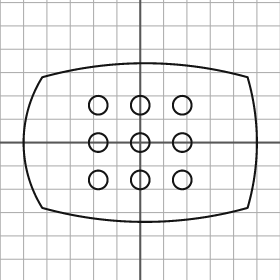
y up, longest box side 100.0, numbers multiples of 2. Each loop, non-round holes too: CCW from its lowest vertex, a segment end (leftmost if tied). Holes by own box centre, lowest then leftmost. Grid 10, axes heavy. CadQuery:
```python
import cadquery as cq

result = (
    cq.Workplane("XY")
    .moveTo(-42.0, -28.0)
    .threePointArc((2.0, -34.0), (46.0, -28.0))
    .threePointArc((50.0, 0.0), (46.0, 28.0))
    .threePointArc((2.0, 34.0), (-42.0, 28.0))
    .threePointArc((-50.0, 0.0), (-42.0, -28.0))
    .close()
    .moveTo(-18.0, -16.0)
    .circle(4.0)
    .moveTo(0.0, -16.0)
    .circle(4.0)
    .moveTo(18.0, -16.0)
    .circle(4.0)
    .moveTo(-18.0, 0.0)
    .circle(4.0)
    .moveTo(0.0, 0.0)
    .circle(4.0)
    .moveTo(18.0, 0.0)
    .circle(4.0)
    .moveTo(-18.0, 16.0)
    .circle(4.0)
    .moveTo(0.0, 16.0)
    .circle(4.0)
    .moveTo(18.0, 16.0)
    .circle(4.0)
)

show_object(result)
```